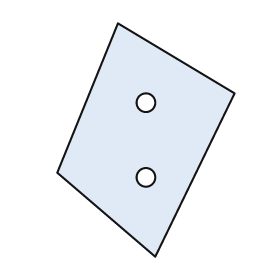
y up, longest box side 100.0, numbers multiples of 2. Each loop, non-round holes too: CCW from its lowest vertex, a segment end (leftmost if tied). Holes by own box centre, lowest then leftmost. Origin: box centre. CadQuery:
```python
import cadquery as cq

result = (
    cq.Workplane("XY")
    .moveTo(4.0, -50.0)
    .lineTo(38.0, 20.0)
    .lineTo(-12.0, 50.0)
    .lineTo(-38.0, -14.0)
    .close()
    .moveTo(0.0, -16.0)
    .circle(4.0)
    .moveTo(0.0, 16.0)
    .circle(4.0)
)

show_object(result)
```